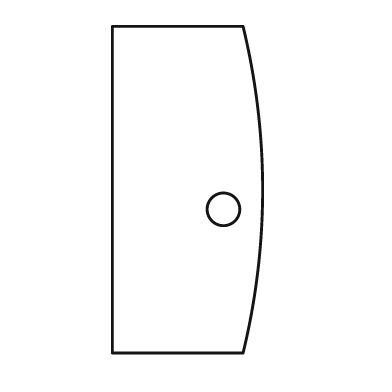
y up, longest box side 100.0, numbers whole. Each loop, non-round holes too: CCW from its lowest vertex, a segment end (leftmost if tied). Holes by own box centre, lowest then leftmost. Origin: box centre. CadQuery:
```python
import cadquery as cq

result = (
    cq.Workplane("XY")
    .moveTo(-23.0, -50.0)
    .lineTo(17.0, -50.0)
    .threePointArc((23.0, 0.0), (17.0, 50.0))
    .lineTo(-23.0, 50.0)
    .close()
    .moveTo(11.0, -6.0)
    .circle(5.0)
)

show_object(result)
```